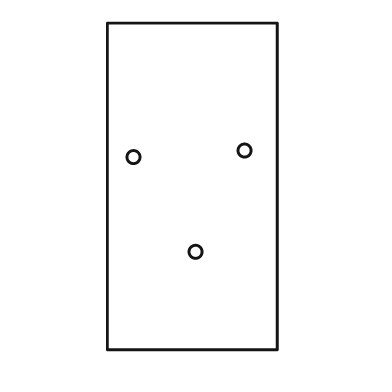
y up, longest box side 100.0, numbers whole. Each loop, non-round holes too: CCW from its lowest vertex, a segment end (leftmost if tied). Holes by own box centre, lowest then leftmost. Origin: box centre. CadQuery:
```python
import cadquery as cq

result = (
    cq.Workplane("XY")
    .moveTo(-26.0, -50.0)
    .lineTo(26.0, -50.0)
    .lineTo(26.0, 50.0)
    .lineTo(-26.0, 50.0)
    .close()
    .moveTo(1.0, -20.0)
    .circle(2.0)
    .moveTo(-18.0, 9.0)
    .circle(2.0)
    .moveTo(16.0, 11.0)
    .circle(2.0)
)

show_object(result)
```